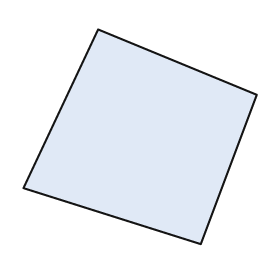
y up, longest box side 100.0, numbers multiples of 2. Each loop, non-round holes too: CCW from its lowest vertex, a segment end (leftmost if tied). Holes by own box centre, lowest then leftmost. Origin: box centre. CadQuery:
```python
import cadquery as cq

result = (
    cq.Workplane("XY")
    .moveTo(26.0, -46.0)
    .lineTo(50.0, 18.0)
    .lineTo(-18.0, 46.0)
    .lineTo(-50.0, -22.0)
    .close()
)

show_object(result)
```